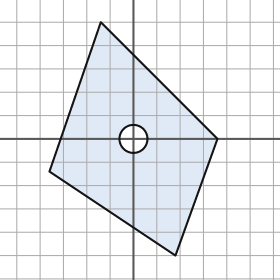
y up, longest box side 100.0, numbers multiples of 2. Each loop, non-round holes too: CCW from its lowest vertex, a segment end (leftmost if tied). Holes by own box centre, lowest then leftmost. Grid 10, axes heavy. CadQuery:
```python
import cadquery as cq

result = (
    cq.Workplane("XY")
    .moveTo(18.0, -50.0)
    .lineTo(36.0, 0.0)
    .lineTo(-14.0, 50.0)
    .lineTo(-36.0, -14.0)
    .close()
    .moveTo(0.0, 0.0)
    .circle(6.0)
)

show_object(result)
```